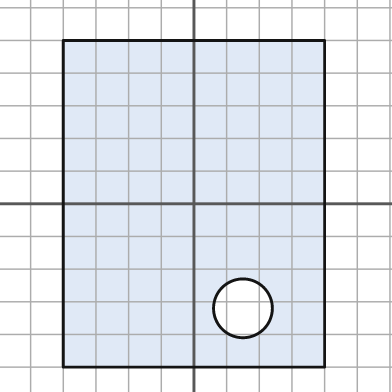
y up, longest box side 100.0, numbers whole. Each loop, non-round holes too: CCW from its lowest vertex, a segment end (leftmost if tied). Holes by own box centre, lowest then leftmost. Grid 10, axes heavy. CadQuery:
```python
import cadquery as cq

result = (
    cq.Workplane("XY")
    .moveTo(-40.0, -50.0)
    .lineTo(40.0, -50.0)
    .lineTo(40.0, 50.0)
    .lineTo(-40.0, 50.0)
    .close()
    .moveTo(15.0, -32.0)
    .circle(9.0)
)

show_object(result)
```